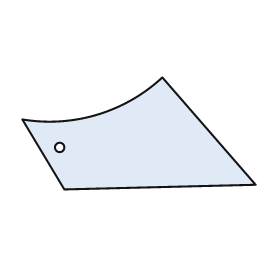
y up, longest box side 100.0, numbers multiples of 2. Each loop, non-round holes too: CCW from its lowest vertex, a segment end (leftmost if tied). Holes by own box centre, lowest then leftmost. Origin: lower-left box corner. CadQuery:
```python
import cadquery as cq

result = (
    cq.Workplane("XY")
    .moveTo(18.0, 0.0)
    .lineTo(100.0, 2.0)
    .lineTo(60.0, 48.0)
    .threePointArc((32.0, 32.0), (0.0, 30.0))
    .close()
    .moveTo(16.0, 18.0)
    .circle(2.0)
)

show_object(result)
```